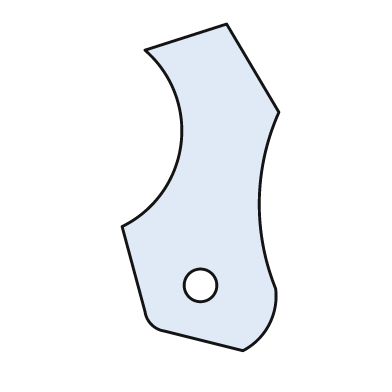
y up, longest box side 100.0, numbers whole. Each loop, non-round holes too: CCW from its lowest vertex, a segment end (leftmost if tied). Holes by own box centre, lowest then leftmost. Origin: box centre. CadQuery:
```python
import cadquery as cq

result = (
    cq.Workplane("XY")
    .moveTo(13.0, -50.0)
    .threePointArc((21.0, -42.0), (23.0, -31.0))
    .threePointArc((18.0, -4.0), (24.0, 23.0))
    .lineTo(8.0, 50.0)
    .lineTo(-17.0, 42.0)
    .threePointArc((-6.0, 13.0), (-24.0, -12.0))
    .lineTo(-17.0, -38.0)
    .threePointArc((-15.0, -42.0), (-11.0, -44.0))
    .close()
    .moveTo(0.0, -30.0)
    .circle(5.0)
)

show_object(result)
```